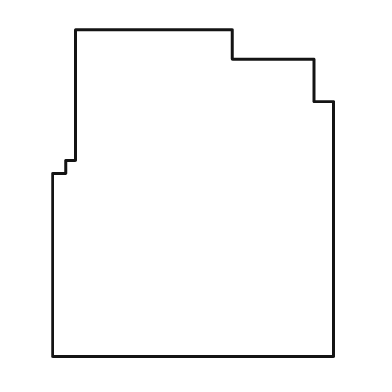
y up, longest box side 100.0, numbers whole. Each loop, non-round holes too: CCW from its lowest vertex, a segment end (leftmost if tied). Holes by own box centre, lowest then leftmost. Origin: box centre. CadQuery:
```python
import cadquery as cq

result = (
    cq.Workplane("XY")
    .moveTo(-43.0, -50.0)
    .lineTo(43.0, -50.0)
    .lineTo(43.0, 28.0)
    .lineTo(37.0, 28.0)
    .lineTo(37.0, 41.0)
    .lineTo(12.0, 41.0)
    .lineTo(12.0, 50.0)
    .lineTo(-36.0, 50.0)
    .lineTo(-36.0, 10.0)
    .lineTo(-39.0, 10.0)
    .lineTo(-39.0, 6.0)
    .lineTo(-43.0, 6.0)
    .close()
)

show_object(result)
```